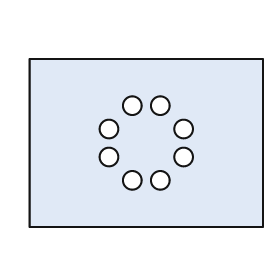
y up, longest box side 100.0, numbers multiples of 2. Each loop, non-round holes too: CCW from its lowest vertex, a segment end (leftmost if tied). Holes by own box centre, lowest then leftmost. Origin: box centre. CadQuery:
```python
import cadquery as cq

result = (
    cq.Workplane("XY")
    .moveTo(-50.0, -36.0)
    .lineTo(50.0, -36.0)
    .lineTo(50.0, 36.0)
    .lineTo(-50.0, 36.0)
    .close()
    .moveTo(-6.0, -16.0)
    .circle(4.0)
    .moveTo(6.0, -16.0)
    .circle(4.0)
    .moveTo(-16.0, -6.0)
    .circle(4.0)
    .moveTo(16.0, -6.0)
    .circle(4.0)
    .moveTo(-16.0, 6.0)
    .circle(4.0)
    .moveTo(16.0, 6.0)
    .circle(4.0)
    .moveTo(-6.0, 16.0)
    .circle(4.0)
    .moveTo(6.0, 16.0)
    .circle(4.0)
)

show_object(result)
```